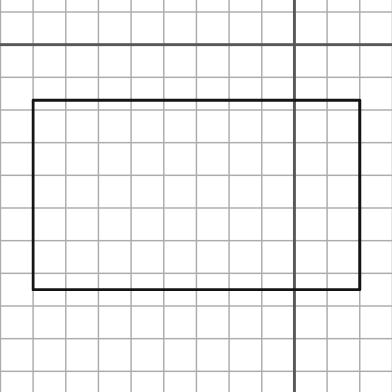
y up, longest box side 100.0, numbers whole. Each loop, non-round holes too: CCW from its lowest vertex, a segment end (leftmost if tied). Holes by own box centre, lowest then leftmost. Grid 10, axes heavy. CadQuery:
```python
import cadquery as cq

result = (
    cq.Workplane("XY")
    .moveTo(-80.0, -75.0)
    .lineTo(20.0, -75.0)
    .lineTo(20.0, -17.0)
    .lineTo(-80.0, -17.0)
    .close()
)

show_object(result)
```